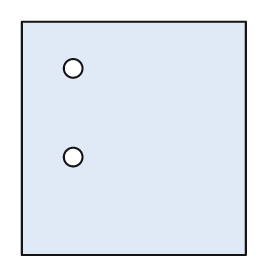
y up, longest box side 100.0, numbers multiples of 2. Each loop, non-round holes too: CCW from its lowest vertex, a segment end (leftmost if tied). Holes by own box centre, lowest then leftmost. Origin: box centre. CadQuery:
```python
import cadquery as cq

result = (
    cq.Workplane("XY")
    .moveTo(-48.0, -50.0)
    .lineTo(48.0, -50.0)
    .lineTo(48.0, 50.0)
    .lineTo(-48.0, 50.0)
    .close()
    .moveTo(-26.0, -8.0)
    .circle(4.0)
    .moveTo(-26.0, 30.0)
    .circle(4.0)
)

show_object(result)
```